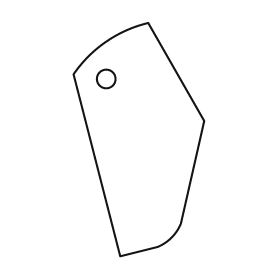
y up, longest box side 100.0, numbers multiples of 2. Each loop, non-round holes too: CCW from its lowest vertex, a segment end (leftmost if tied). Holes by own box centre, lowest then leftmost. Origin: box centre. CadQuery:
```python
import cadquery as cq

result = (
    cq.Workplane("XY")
    .moveTo(-8.0, -50.0)
    .lineTo(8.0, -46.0)
    .threePointArc((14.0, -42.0), (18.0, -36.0))
    .lineTo(28.0, 8.0)
    .lineTo(4.0, 50.0)
    .threePointArc((-14.0, 42.0), (-28.0, 28.0))
    .close()
    .moveTo(-14.0, 26.0)
    .circle(4.0)
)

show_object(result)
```